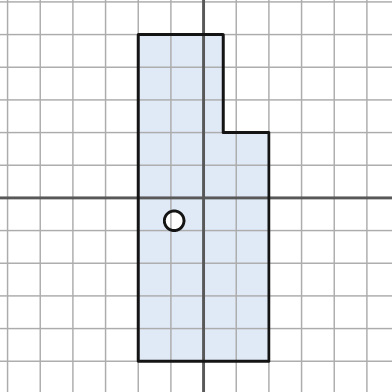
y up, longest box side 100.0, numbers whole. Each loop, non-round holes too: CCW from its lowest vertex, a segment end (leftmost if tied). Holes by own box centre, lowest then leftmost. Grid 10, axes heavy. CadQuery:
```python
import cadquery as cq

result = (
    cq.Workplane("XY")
    .moveTo(-20.0, -50.0)
    .lineTo(20.0, -50.0)
    .lineTo(20.0, 20.0)
    .lineTo(6.0, 20.0)
    .lineTo(6.0, 50.0)
    .lineTo(-20.0, 50.0)
    .close()
    .moveTo(-9.0, -7.0)
    .circle(3.0)
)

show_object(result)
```